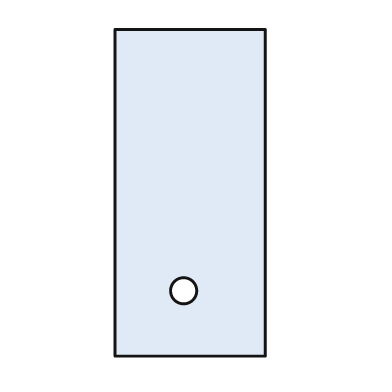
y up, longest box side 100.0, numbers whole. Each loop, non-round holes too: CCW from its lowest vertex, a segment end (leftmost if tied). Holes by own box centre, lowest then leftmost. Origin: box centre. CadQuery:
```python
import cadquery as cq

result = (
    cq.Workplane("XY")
    .moveTo(-23.0, -50.0)
    .lineTo(23.0, -50.0)
    .lineTo(23.0, 50.0)
    .lineTo(-23.0, 50.0)
    .close()
    .moveTo(-2.0, -30.0)
    .circle(4.0)
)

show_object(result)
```